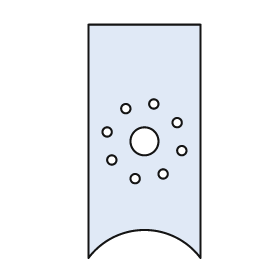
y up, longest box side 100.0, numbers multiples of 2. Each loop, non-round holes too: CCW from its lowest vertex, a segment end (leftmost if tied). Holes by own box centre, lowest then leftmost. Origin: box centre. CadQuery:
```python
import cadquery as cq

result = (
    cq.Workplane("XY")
    .moveTo(-24.0, -50.0)
    .threePointArc((0.0, -38.0), (24.0, -50.0))
    .lineTo(24.0, 50.0)
    .lineTo(-24.0, 50.0)
    .close()
    .moveTo(-4.0, -16.0)
    .circle(2.0)
    .moveTo(8.0, -14.0)
    .circle(2.0)
    .moveTo(-14.0, -8.0)
    .circle(2.0)
    .moveTo(16.0, -4.0)
    .circle(2.0)
    .moveTo(0.0, 0.0)
    .circle(6.0)
    .moveTo(-16.0, 4.0)
    .circle(2.0)
    .moveTo(14.0, 8.0)
    .circle(2.0)
    .moveTo(-8.0, 14.0)
    .circle(2.0)
    .moveTo(4.0, 16.0)
    .circle(2.0)
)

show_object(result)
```